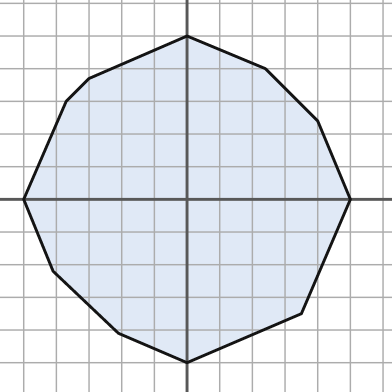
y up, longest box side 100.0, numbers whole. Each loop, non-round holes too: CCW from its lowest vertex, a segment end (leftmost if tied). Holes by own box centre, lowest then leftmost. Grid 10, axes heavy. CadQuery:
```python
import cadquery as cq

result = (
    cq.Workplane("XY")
    .moveTo(0.0, -50.0)
    .lineTo(35.0, -35.0)
    .lineTo(50.0, 0.0)
    .lineTo(40.0, 24.0)
    .lineTo(24.0, 40.0)
    .lineTo(0.0, 50.0)
    .lineTo(-30.0, 37.0)
    .lineTo(-37.0, 30.0)
    .lineTo(-50.0, 0.0)
    .lineTo(-41.0, -22.0)
    .lineTo(-21.0, -41.0)
    .close()
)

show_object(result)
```